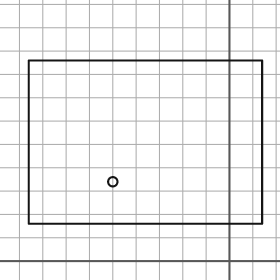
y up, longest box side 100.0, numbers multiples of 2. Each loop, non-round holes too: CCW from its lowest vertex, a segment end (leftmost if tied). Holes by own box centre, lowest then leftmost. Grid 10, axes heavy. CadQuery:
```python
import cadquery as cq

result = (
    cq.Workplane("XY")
    .moveTo(-86.0, 16.0)
    .lineTo(14.0, 16.0)
    .lineTo(14.0, 86.0)
    .lineTo(-86.0, 86.0)
    .close()
    .moveTo(-50.0, 34.0)
    .circle(2.0)
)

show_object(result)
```